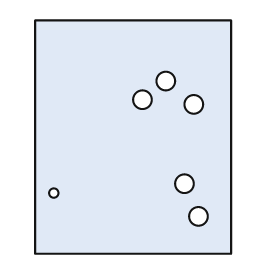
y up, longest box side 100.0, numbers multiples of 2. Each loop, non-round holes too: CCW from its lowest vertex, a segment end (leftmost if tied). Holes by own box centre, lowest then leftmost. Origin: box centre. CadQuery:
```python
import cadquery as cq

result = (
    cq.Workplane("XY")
    .moveTo(-42.0, -50.0)
    .lineTo(42.0, -50.0)
    .lineTo(42.0, 50.0)
    .lineTo(-42.0, 50.0)
    .close()
    .moveTo(28.0, -34.0)
    .circle(4.0)
    .moveTo(-34.0, -24.0)
    .circle(2.0)
    .moveTo(22.0, -20.0)
    .circle(4.0)
    .moveTo(26.0, 14.0)
    .circle(4.0)
    .moveTo(4.0, 16.0)
    .circle(4.0)
    .moveTo(14.0, 24.0)
    .circle(4.0)
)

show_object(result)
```